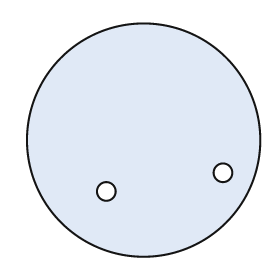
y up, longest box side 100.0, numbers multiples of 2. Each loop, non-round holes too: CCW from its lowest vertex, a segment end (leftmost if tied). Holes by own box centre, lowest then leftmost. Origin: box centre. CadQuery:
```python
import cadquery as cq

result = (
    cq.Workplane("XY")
    .moveTo(0.0, 0.0)
    .circle(50.0)
    .moveTo(-16.0, -22.0)
    .circle(4.0)
    .moveTo(34.0, -14.0)
    .circle(4.0)
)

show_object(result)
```